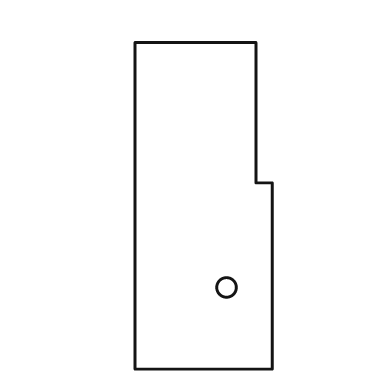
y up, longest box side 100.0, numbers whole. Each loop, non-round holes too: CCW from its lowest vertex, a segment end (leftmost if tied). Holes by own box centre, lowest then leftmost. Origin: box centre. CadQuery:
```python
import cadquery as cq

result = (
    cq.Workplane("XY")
    .moveTo(-21.0, -50.0)
    .lineTo(21.0, -50.0)
    .lineTo(21.0, 7.0)
    .lineTo(16.0, 7.0)
    .lineTo(16.0, 50.0)
    .lineTo(-21.0, 50.0)
    .close()
    .moveTo(7.0, -25.0)
    .circle(3.0)
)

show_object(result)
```